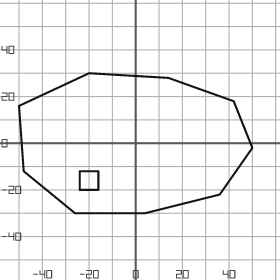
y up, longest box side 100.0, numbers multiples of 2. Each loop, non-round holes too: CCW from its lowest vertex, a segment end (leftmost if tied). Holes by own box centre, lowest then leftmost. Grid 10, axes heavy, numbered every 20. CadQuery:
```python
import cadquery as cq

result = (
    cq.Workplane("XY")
    .moveTo(-26.0, -30.0)
    .lineTo(4.0, -30.0)
    .lineTo(36.0, -22.0)
    .lineTo(50.0, -2.0)
    .lineTo(42.0, 18.0)
    .lineTo(14.0, 28.0)
    .lineTo(-20.0, 30.0)
    .lineTo(-50.0, 16.0)
    .lineTo(-48.0, -12.0)
    .close()
    .moveTo(-24.0, -20.0)
    .lineTo(-16.0, -20.0)
    .lineTo(-16.0, -12.0)
    .lineTo(-24.0, -12.0)
    .close()
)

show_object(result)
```